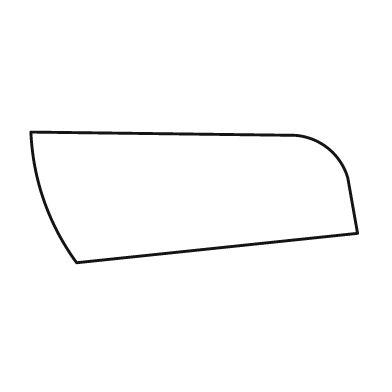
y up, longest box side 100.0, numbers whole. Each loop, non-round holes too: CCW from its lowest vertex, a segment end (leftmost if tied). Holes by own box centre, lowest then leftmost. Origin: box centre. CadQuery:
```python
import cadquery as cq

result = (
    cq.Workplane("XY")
    .moveTo(-36.0, -20.0)
    .lineTo(50.0, -11.0)
    .lineTo(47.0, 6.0)
    .threePointArc((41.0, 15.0), (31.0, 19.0))
    .lineTo(-50.0, 20.0)
    .threePointArc((-46.0, -1.0), (-36.0, -20.0))
    .close()
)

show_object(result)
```